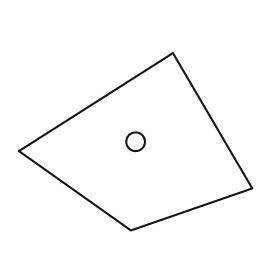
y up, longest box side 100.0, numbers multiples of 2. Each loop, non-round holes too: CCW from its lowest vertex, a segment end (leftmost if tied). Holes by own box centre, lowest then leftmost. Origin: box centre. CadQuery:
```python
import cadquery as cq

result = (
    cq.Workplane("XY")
    .moveTo(-2.0, -38.0)
    .lineTo(50.0, -20.0)
    .lineTo(16.0, 38.0)
    .lineTo(-50.0, -4.0)
    .close()
    .moveTo(0.0, 0.0)
    .circle(4.0)
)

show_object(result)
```